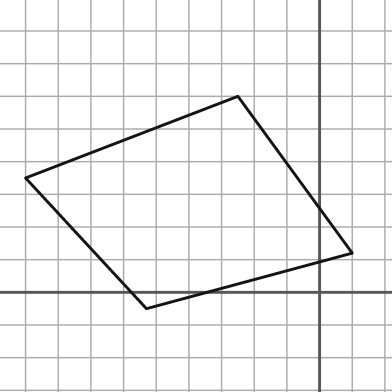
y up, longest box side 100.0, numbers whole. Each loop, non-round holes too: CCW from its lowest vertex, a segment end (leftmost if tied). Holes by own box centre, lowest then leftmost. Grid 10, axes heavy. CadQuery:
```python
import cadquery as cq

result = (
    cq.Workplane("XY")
    .moveTo(-53.0, -5.0)
    .lineTo(10.0, 12.0)
    .lineTo(-25.0, 60.0)
    .lineTo(-90.0, 35.0)
    .close()
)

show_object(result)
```